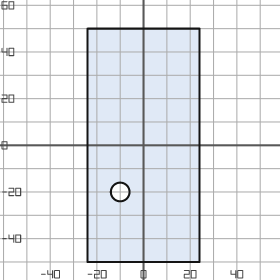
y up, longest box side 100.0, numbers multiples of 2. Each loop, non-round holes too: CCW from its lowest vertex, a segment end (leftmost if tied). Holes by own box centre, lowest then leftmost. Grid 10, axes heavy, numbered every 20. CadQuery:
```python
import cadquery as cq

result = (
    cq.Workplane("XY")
    .moveTo(-24.0, -50.0)
    .lineTo(24.0, -50.0)
    .lineTo(24.0, 50.0)
    .lineTo(-24.0, 50.0)
    .close()
    .moveTo(-10.0, -20.0)
    .circle(4.0)
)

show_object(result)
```